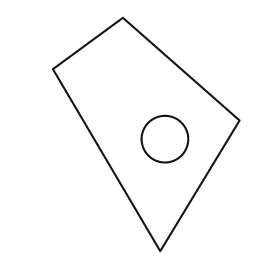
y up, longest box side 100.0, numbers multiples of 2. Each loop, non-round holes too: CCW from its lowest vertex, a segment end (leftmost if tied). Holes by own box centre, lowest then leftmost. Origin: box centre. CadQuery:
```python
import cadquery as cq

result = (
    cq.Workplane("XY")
    .moveTo(6.0, -50.0)
    .lineTo(40.0, 6.0)
    .lineTo(-10.0, 50.0)
    .lineTo(-40.0, 28.0)
    .close()
    .moveTo(8.0, -2.0)
    .circle(10.0)
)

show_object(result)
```